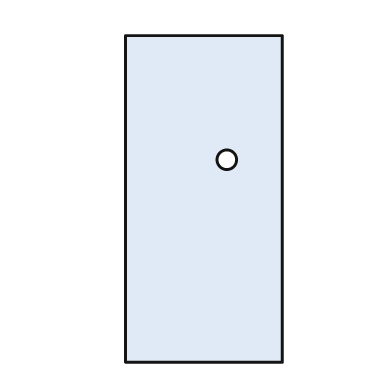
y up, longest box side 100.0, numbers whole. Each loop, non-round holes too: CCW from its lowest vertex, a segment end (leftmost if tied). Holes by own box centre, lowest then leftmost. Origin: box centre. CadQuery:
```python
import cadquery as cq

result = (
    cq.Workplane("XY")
    .moveTo(-24.0, -50.0)
    .lineTo(24.0, -50.0)
    .lineTo(24.0, 50.0)
    .lineTo(-24.0, 50.0)
    .close()
    .moveTo(7.0, 12.0)
    .circle(3.0)
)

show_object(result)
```